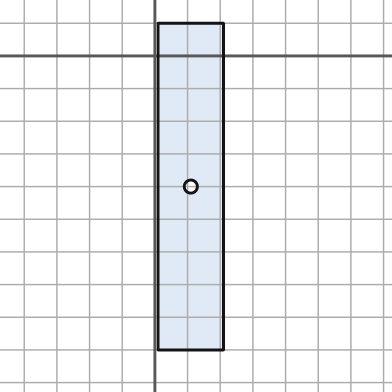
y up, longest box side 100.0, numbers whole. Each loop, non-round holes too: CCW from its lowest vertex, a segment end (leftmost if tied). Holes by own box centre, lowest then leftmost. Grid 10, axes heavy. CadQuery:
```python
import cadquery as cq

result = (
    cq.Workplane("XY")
    .moveTo(1.0, -90.0)
    .lineTo(21.0, -90.0)
    .lineTo(21.0, 10.0)
    .lineTo(1.0, 10.0)
    .close()
    .moveTo(11.0, -40.0)
    .circle(2.0)
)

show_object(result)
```